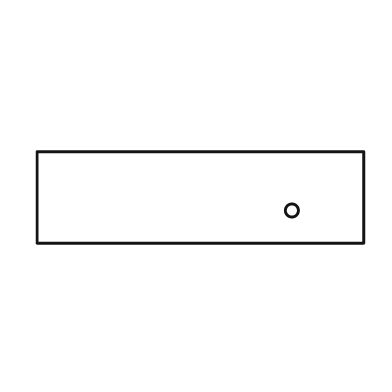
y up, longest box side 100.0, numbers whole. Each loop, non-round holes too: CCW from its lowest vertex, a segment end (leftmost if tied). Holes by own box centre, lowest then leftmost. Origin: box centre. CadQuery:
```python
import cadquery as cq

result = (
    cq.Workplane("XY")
    .moveTo(-50.0, -14.0)
    .lineTo(50.0, -14.0)
    .lineTo(50.0, 14.0)
    .lineTo(-50.0, 14.0)
    .close()
    .moveTo(28.0, -4.0)
    .circle(2.0)
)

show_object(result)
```